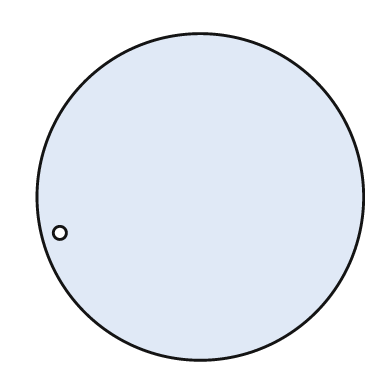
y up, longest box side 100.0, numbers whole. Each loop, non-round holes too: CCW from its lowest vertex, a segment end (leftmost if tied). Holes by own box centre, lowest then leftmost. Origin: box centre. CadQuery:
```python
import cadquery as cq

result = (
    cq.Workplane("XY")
    .moveTo(0.0, 0.0)
    .circle(50.0)
    .moveTo(-43.0, -11.0)
    .circle(2.0)
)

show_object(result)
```